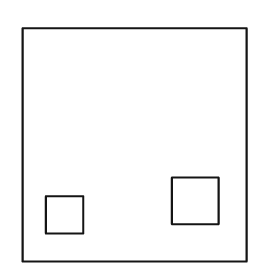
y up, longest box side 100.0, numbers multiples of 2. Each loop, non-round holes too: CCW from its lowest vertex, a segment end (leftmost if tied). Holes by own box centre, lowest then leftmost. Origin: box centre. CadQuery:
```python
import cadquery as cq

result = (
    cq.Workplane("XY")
    .moveTo(-48.0, -50.0)
    .lineTo(48.0, -50.0)
    .lineTo(48.0, 50.0)
    .lineTo(-48.0, 50.0)
    .close()
    .moveTo(-38.0, -38.0)
    .lineTo(-22.0, -38.0)
    .lineTo(-22.0, -22.0)
    .lineTo(-38.0, -22.0)
    .close()
    .moveTo(16.0, -34.0)
    .lineTo(36.0, -34.0)
    .lineTo(36.0, -14.0)
    .lineTo(16.0, -14.0)
    .close()
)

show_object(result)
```